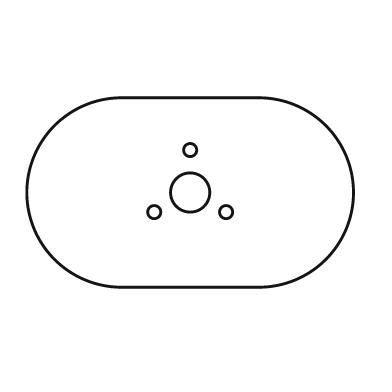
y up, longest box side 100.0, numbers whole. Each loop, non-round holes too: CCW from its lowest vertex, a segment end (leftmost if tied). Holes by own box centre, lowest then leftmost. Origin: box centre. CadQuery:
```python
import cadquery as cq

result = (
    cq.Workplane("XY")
    .moveTo(-21.0, -29.0)
    .lineTo(21.0, -29.0)
    .threePointArc((50.0, 0.0), (21.0, 29.0))
    .lineTo(-21.0, 29.0)
    .threePointArc((-50.0, 0.0), (-21.0, -29.0))
    .close()
    .moveTo(-11.0, -6.0)
    .circle(2.0)
    .moveTo(11.0, -6.0)
    .circle(2.0)
    .moveTo(0.0, 0.0)
    .circle(6.0)
    .moveTo(0.0, 13.0)
    .circle(2.0)
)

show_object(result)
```